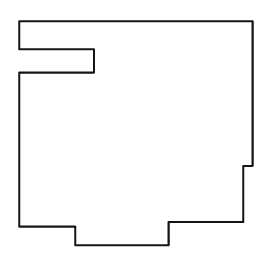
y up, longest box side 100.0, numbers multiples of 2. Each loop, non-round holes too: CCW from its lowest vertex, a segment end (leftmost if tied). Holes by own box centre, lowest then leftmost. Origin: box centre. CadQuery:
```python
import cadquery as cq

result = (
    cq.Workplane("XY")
    .moveTo(-26.0, -48.0)
    .lineTo(14.0, -48.0)
    .lineTo(14.0, -38.0)
    .lineTo(46.0, -38.0)
    .lineTo(46.0, -14.0)
    .lineTo(50.0, -14.0)
    .lineTo(50.0, 48.0)
    .lineTo(-50.0, 48.0)
    .lineTo(-50.0, 36.0)
    .lineTo(-18.0, 36.0)
    .lineTo(-18.0, 26.0)
    .lineTo(-50.0, 26.0)
    .lineTo(-50.0, -40.0)
    .lineTo(-26.0, -40.0)
    .close()
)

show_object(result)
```